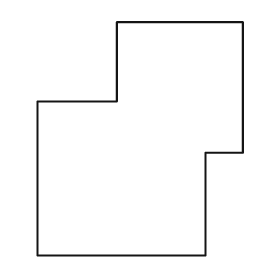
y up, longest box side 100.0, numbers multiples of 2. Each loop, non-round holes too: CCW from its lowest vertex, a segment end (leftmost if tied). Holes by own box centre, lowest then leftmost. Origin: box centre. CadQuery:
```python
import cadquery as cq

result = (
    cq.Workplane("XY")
    .moveTo(-44.0, -50.0)
    .lineTo(28.0, -50.0)
    .lineTo(28.0, -6.0)
    .lineTo(44.0, -6.0)
    .lineTo(44.0, 50.0)
    .lineTo(-10.0, 50.0)
    .lineTo(-10.0, 16.0)
    .lineTo(-44.0, 16.0)
    .close()
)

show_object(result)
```